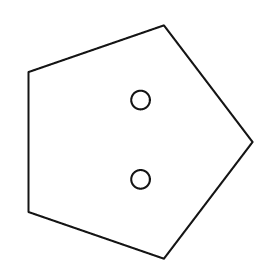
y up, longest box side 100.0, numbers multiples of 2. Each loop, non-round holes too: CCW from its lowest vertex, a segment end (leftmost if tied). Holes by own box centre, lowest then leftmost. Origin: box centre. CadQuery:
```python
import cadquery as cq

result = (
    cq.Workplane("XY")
    .moveTo(10.0, -50.0)
    .lineTo(48.0, 0.0)
    .lineTo(10.0, 50.0)
    .lineTo(-48.0, 30.0)
    .lineTo(-48.0, -30.0)
    .close()
    .moveTo(0.0, -16.0)
    .circle(4.0)
    .moveTo(0.0, 18.0)
    .circle(4.0)
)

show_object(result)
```